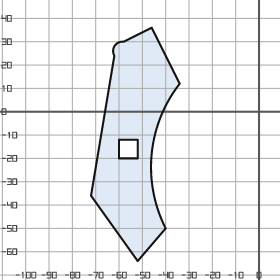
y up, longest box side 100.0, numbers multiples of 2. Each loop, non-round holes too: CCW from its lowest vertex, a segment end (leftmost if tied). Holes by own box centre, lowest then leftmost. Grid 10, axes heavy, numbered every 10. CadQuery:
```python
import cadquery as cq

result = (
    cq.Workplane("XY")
    .moveTo(-52.0, -64.0)
    .lineTo(-40.0, -50.0)
    .threePointArc((-46.0, -18.0), (-34.0, 12.0))
    .lineTo(-46.0, 36.0)
    .lineTo(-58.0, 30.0)
    .threePointArc((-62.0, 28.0), (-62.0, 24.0))
    .lineTo(-72.0, -36.0)
    .close()
    .moveTo(-60.0, -20.0)
    .lineTo(-52.0, -20.0)
    .lineTo(-52.0, -12.0)
    .lineTo(-60.0, -12.0)
    .close()
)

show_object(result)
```